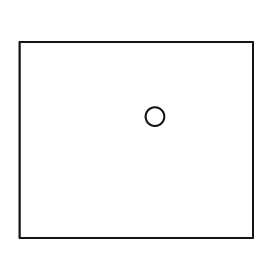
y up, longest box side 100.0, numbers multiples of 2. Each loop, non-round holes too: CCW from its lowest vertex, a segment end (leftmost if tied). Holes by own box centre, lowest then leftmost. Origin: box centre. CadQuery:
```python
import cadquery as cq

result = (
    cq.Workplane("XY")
    .moveTo(-50.0, -42.0)
    .lineTo(50.0, -42.0)
    .lineTo(50.0, 42.0)
    .lineTo(-50.0, 42.0)
    .close()
    .moveTo(8.0, 10.0)
    .circle(4.0)
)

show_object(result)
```